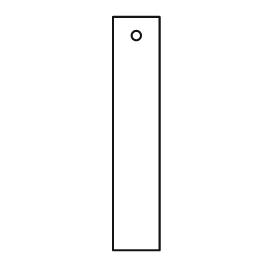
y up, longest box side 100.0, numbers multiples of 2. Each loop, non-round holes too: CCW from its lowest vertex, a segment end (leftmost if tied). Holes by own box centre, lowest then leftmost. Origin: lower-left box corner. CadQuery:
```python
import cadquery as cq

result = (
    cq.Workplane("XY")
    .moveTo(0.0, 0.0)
    .lineTo(20.0, 0.0)
    .lineTo(20.0, 100.0)
    .lineTo(0.0, 100.0)
    .close()
    .moveTo(10.0, 92.0)
    .circle(2.0)
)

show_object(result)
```